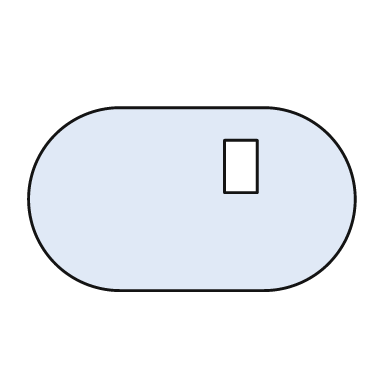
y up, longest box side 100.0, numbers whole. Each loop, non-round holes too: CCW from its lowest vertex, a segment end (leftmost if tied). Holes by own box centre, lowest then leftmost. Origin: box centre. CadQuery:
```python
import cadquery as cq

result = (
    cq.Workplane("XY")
    .moveTo(-22.0, -28.0)
    .lineTo(22.0, -28.0)
    .threePointArc((50.0, 0.0), (22.0, 28.0))
    .lineTo(-22.0, 28.0)
    .threePointArc((-50.0, 0.0), (-22.0, -28.0))
    .close()
    .moveTo(10.0, 2.0)
    .lineTo(20.0, 2.0)
    .lineTo(20.0, 18.0)
    .lineTo(10.0, 18.0)
    .close()
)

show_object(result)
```